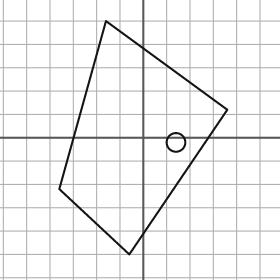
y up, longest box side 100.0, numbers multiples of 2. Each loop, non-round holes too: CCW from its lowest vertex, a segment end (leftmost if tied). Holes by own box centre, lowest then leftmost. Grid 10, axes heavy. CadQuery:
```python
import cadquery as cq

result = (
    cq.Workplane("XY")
    .moveTo(-6.0, -50.0)
    .lineTo(36.0, 12.0)
    .lineTo(-16.0, 50.0)
    .lineTo(-36.0, -22.0)
    .close()
    .moveTo(14.0, -2.0)
    .circle(4.0)
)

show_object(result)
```